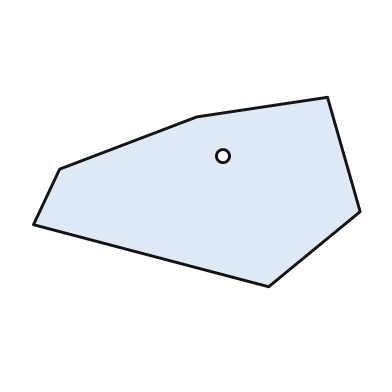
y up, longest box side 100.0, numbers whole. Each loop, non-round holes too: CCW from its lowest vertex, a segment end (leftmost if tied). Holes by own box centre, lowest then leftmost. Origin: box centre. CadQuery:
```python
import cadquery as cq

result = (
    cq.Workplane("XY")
    .moveTo(22.0, -29.0)
    .lineTo(50.0, -6.0)
    .lineTo(40.0, 29.0)
    .lineTo(0.0, 23.0)
    .lineTo(-42.0, 7.0)
    .lineTo(-50.0, -10.0)
    .close()
    .moveTo(8.0, 11.0)
    .circle(2.0)
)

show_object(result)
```